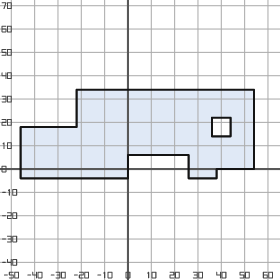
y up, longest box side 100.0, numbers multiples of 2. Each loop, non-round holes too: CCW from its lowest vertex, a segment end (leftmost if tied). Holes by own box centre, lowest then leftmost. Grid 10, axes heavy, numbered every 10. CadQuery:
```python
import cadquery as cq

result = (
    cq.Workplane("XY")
    .moveTo(-46.0, -4.0)
    .lineTo(0.0, -4.0)
    .lineTo(0.0, 6.0)
    .lineTo(26.0, 6.0)
    .lineTo(26.0, -4.0)
    .lineTo(38.0, -4.0)
    .lineTo(38.0, 0.0)
    .lineTo(54.0, 0.0)
    .lineTo(54.0, 34.0)
    .lineTo(-22.0, 34.0)
    .lineTo(-22.0, 18.0)
    .lineTo(-46.0, 18.0)
    .close()
    .moveTo(36.0, 14.0)
    .lineTo(44.0, 14.0)
    .lineTo(44.0, 22.0)
    .lineTo(36.0, 22.0)
    .close()
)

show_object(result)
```